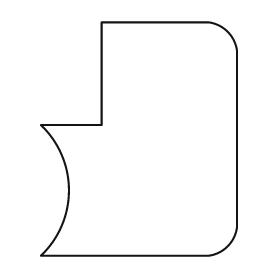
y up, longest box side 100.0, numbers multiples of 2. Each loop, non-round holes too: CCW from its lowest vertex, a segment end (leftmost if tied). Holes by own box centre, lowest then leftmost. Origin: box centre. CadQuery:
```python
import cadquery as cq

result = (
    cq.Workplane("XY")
    .moveTo(-42.0, -50.0)
    .lineTo(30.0, -50.0)
    .threePointArc((38.0, -46.0), (42.0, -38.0))
    .lineTo(42.0, 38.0)
    .threePointArc((38.0, 46.0), (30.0, 50.0))
    .lineTo(-16.0, 50.0)
    .lineTo(-16.0, 6.0)
    .lineTo(-42.0, 6.0)
    .threePointArc((-30.0, -22.0), (-42.0, -50.0))
    .close()
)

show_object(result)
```